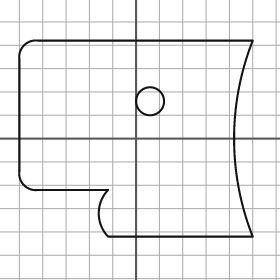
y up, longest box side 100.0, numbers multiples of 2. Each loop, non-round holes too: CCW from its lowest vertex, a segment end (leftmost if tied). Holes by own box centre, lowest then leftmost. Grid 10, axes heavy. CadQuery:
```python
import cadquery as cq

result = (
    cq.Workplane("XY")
    .moveTo(-12.0, -42.0)
    .lineTo(50.0, -42.0)
    .threePointArc((42.0, 0.0), (50.0, 42.0))
    .lineTo(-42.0, 42.0)
    .threePointArc((-48.0, 40.0), (-50.0, 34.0))
    .lineTo(-50.0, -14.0)
    .threePointArc((-48.0, -20.0), (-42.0, -22.0))
    .lineTo(-12.0, -22.0)
    .threePointArc((-16.0, -32.0), (-12.0, -42.0))
    .close()
    .moveTo(6.0, 16.0)
    .circle(6.0)
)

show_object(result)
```